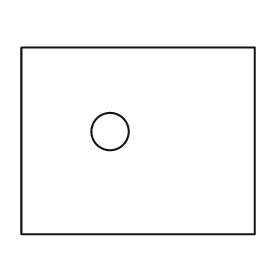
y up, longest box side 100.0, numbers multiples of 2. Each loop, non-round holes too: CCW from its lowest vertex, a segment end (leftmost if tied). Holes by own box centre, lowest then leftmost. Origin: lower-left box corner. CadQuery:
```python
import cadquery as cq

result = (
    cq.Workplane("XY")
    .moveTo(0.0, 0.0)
    .lineTo(100.0, 0.0)
    .lineTo(100.0, 80.0)
    .lineTo(0.0, 80.0)
    .close()
    .moveTo(38.0, 44.0)
    .circle(8.0)
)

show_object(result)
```